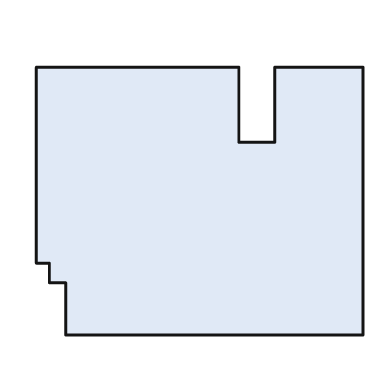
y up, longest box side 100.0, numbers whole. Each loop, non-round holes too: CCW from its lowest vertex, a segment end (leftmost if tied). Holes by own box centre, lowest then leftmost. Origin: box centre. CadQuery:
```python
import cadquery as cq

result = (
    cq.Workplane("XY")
    .moveTo(-41.0, -41.0)
    .lineTo(50.0, -41.0)
    .lineTo(50.0, 41.0)
    .lineTo(23.0, 41.0)
    .lineTo(23.0, 18.0)
    .lineTo(12.0, 18.0)
    .lineTo(12.0, 41.0)
    .lineTo(-50.0, 41.0)
    .lineTo(-50.0, -19.0)
    .lineTo(-46.0, -19.0)
    .lineTo(-46.0, -25.0)
    .lineTo(-41.0, -25.0)
    .close()
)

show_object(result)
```